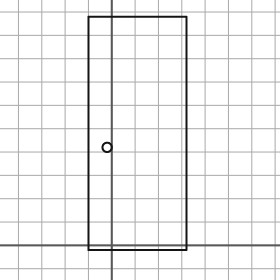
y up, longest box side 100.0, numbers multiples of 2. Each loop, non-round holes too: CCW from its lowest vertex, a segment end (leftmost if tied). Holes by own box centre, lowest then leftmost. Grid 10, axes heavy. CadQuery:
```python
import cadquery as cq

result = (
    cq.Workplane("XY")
    .moveTo(-10.0, -2.0)
    .lineTo(32.0, -2.0)
    .lineTo(32.0, 98.0)
    .lineTo(-10.0, 98.0)
    .close()
    .moveTo(-2.0, 42.0)
    .circle(2.0)
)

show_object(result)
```